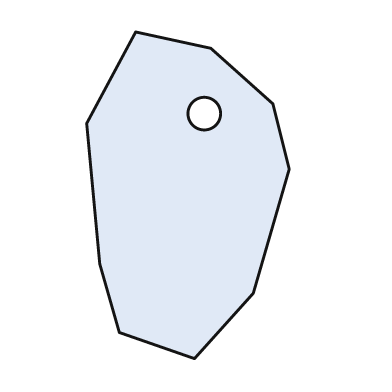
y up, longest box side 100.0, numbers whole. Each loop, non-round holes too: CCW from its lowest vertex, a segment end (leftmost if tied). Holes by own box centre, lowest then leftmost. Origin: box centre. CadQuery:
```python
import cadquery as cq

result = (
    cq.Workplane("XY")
    .moveTo(2.0, -50.0)
    .lineTo(20.0, -30.0)
    .lineTo(31.0, 8.0)
    .lineTo(26.0, 28.0)
    .lineTo(7.0, 45.0)
    .lineTo(-16.0, 50.0)
    .lineTo(-31.0, 22.0)
    .lineTo(-27.0, -21.0)
    .lineTo(-21.0, -42.0)
    .close()
    .moveTo(5.0, 25.0)
    .circle(5.0)
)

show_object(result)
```